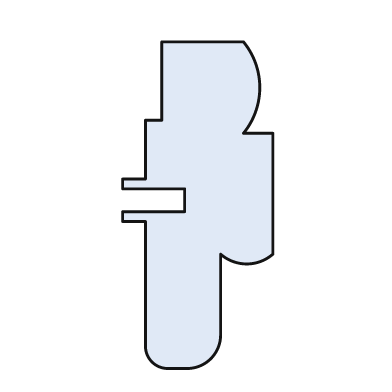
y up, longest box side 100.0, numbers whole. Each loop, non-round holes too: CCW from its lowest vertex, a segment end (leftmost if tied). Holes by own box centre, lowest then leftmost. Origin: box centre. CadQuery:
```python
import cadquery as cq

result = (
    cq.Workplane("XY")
    .moveTo(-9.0, -50.0)
    .lineTo(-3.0, -50.0)
    .threePointArc((4.0, -47.0), (7.0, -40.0))
    .lineTo(7.0, -15.0)
    .threePointArc((15.0, -18.0), (23.0, -15.0))
    .lineTo(23.0, 22.0)
    .lineTo(14.0, 22.0)
    .threePointArc((19.0, 36.0), (14.0, 50.0))
    .lineTo(-11.0, 50.0)
    .lineTo(-11.0, 26.0)
    .lineTo(-16.0, 26.0)
    .lineTo(-16.0, 8.0)
    .lineTo(-23.0, 8.0)
    .lineTo(-23.0, 5.0)
    .lineTo(-4.0, 5.0)
    .lineTo(-4.0, -2.0)
    .lineTo(-23.0, -2.0)
    .lineTo(-23.0, -5.0)
    .lineTo(-16.0, -5.0)
    .lineTo(-16.0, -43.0)
    .threePointArc((-14.0, -48.0), (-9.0, -50.0))
    .close()
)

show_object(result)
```